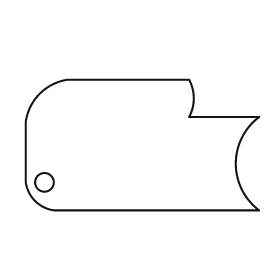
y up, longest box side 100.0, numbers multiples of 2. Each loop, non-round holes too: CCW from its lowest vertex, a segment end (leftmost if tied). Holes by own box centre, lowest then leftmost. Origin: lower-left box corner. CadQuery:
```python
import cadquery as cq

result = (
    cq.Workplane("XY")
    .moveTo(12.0, 0.0)
    .lineTo(100.0, 0.0)
    .threePointArc((90.0, 20.0), (100.0, 40.0))
    .lineTo(70.0, 40.0)
    .threePointArc((72.0, 48.0), (70.0, 56.0))
    .lineTo(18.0, 56.0)
    .threePointArc((6.0, 50.0), (0.0, 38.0))
    .lineTo(0.0, 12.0)
    .threePointArc((4.0, 4.0), (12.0, 0.0))
    .close()
    .moveTo(8.0, 12.0)
    .circle(4.0)
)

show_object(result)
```